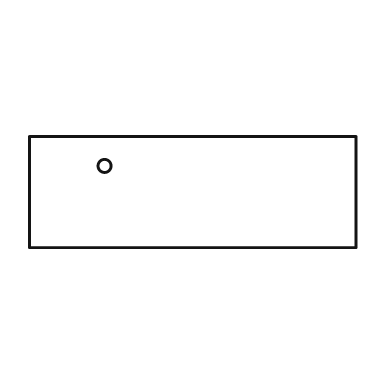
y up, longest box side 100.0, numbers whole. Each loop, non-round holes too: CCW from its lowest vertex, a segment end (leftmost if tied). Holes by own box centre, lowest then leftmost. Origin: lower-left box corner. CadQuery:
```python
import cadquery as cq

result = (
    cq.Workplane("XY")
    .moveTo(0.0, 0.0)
    .lineTo(100.0, 0.0)
    .lineTo(100.0, 34.0)
    .lineTo(0.0, 34.0)
    .close()
    .moveTo(23.0, 25.0)
    .circle(2.0)
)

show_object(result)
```